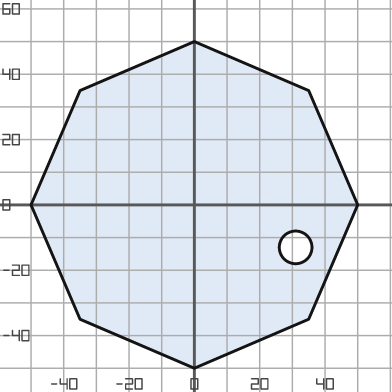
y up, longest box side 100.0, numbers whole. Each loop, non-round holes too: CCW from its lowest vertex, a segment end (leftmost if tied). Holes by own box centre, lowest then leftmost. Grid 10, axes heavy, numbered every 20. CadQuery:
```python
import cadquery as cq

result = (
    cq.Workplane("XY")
    .moveTo(0.0, -50.0)
    .lineTo(35.0, -35.0)
    .lineTo(50.0, 0.0)
    .lineTo(35.0, 35.0)
    .lineTo(0.0, 50.0)
    .lineTo(-35.0, 35.0)
    .lineTo(-50.0, 0.0)
    .lineTo(-35.0, -35.0)
    .close()
    .moveTo(31.0, -13.0)
    .circle(5.0)
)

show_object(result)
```